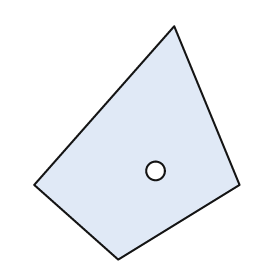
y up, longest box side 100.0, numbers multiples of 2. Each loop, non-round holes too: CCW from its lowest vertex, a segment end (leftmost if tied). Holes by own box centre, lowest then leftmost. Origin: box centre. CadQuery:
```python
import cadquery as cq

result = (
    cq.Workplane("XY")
    .moveTo(-8.0, -50.0)
    .lineTo(44.0, -18.0)
    .lineTo(16.0, 50.0)
    .lineTo(-44.0, -18.0)
    .close()
    .moveTo(8.0, -12.0)
    .circle(4.0)
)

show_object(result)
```